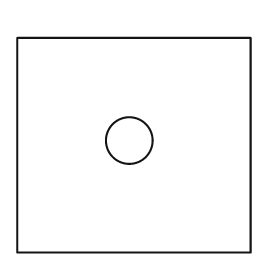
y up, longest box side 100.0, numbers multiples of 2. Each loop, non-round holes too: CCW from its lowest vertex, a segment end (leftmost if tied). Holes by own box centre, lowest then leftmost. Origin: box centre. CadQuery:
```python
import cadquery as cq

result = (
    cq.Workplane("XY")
    .moveTo(-50.0, -46.0)
    .lineTo(50.0, -46.0)
    .lineTo(50.0, 46.0)
    .lineTo(-50.0, 46.0)
    .close()
    .moveTo(-2.0, 2.0)
    .circle(10.0)
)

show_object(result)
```